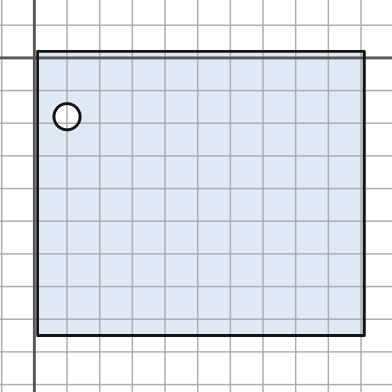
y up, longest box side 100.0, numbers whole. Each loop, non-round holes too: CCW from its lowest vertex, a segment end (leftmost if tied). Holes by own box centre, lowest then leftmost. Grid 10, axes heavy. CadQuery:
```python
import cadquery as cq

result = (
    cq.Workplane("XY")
    .moveTo(1.0, -85.0)
    .lineTo(101.0, -85.0)
    .lineTo(101.0, 2.0)
    .lineTo(1.0, 2.0)
    .close()
    .moveTo(10.0, -18.0)
    .circle(4.0)
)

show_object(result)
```